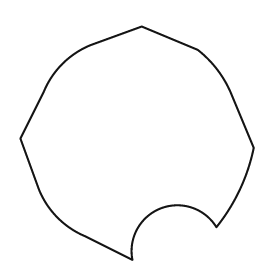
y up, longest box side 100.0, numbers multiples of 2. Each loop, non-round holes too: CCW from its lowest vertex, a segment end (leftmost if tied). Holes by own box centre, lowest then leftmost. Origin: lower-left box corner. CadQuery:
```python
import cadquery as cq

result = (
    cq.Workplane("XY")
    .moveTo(48.0, 0.0)
    .threePointArc((60.0, 22.0), (84.0, 14.0))
    .threePointArc((94.0, 30.0), (100.0, 48.0))
    .lineTo(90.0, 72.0)
    .threePointArc((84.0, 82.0), (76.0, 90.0))
    .lineTo(52.0, 100.0)
    .lineTo(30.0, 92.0)
    .threePointArc((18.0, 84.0), (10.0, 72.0))
    .lineTo(0.0, 52.0)
    .lineTo(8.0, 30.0)
    .threePointArc((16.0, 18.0), (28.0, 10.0))
    .close()
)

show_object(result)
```